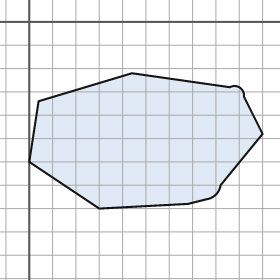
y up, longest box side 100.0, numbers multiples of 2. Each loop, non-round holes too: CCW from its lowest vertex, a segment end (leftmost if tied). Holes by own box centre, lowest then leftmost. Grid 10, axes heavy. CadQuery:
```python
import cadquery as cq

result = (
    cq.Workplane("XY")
    .moveTo(30.0, -80.0)
    .lineTo(68.0, -78.0)
    .lineTo(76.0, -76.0)
    .threePointArc((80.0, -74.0), (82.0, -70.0))
    .lineTo(100.0, -48.0)
    .lineTo(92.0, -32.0)
    .threePointArc((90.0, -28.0), (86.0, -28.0))
    .lineTo(44.0, -22.0)
    .lineTo(4.0, -34.0)
    .lineTo(0.0, -60.0)
    .close()
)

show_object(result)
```